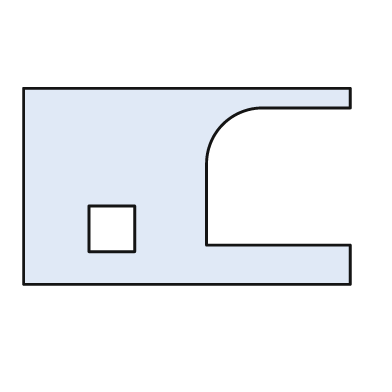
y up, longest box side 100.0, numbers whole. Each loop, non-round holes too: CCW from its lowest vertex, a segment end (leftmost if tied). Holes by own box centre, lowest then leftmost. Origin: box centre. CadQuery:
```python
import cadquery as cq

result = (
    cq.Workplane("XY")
    .moveTo(-50.0, -30.0)
    .lineTo(50.0, -30.0)
    .lineTo(50.0, -18.0)
    .lineTo(6.0, -18.0)
    .lineTo(6.0, 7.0)
    .threePointArc((11.0, 19.0), (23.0, 24.0))
    .lineTo(50.0, 24.0)
    .lineTo(50.0, 30.0)
    .lineTo(-50.0, 30.0)
    .close()
    .moveTo(-30.0, -20.0)
    .lineTo(-16.0, -20.0)
    .lineTo(-16.0, -6.0)
    .lineTo(-30.0, -6.0)
    .close()
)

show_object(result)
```